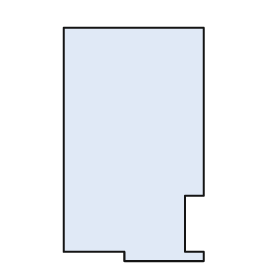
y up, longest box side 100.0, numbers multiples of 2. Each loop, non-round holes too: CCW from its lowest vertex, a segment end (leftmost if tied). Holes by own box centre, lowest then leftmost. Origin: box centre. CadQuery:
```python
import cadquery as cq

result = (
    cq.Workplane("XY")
    .moveTo(-4.0, -50.0)
    .lineTo(30.0, -50.0)
    .lineTo(30.0, -46.0)
    .lineTo(22.0, -46.0)
    .lineTo(22.0, -22.0)
    .lineTo(30.0, -22.0)
    .lineTo(30.0, 50.0)
    .lineTo(-30.0, 50.0)
    .lineTo(-30.0, -46.0)
    .lineTo(-4.0, -46.0)
    .close()
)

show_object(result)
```